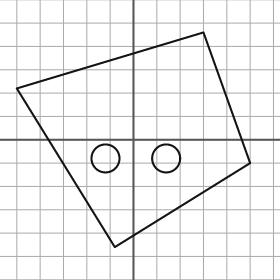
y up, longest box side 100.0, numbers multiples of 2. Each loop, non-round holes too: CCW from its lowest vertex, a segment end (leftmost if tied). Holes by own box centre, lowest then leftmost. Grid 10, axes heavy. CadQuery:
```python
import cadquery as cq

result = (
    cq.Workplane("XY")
    .moveTo(-8.0, -46.0)
    .lineTo(50.0, -10.0)
    .lineTo(30.0, 46.0)
    .lineTo(-50.0, 22.0)
    .close()
    .moveTo(-12.0, -8.0)
    .circle(6.0)
    .moveTo(14.0, -8.0)
    .circle(6.0)
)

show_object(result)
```